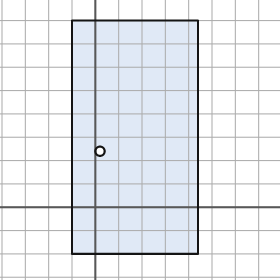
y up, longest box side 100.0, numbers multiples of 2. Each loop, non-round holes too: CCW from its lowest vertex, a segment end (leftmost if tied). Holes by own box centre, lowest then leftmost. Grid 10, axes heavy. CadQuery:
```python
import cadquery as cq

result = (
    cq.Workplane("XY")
    .moveTo(-10.0, -20.0)
    .lineTo(44.0, -20.0)
    .lineTo(44.0, 80.0)
    .lineTo(-10.0, 80.0)
    .close()
    .moveTo(2.0, 24.0)
    .circle(2.0)
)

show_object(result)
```